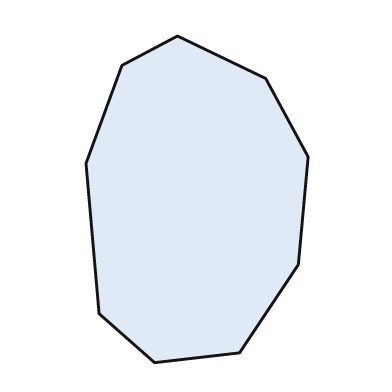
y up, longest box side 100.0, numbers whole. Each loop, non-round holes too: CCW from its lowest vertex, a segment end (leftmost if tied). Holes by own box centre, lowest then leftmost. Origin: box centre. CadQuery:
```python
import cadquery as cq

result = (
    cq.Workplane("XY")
    .moveTo(-13.0, -50.0)
    .lineTo(13.0, -47.0)
    .lineTo(31.0, -20.0)
    .lineTo(34.0, 13.0)
    .lineTo(21.0, 37.0)
    .lineTo(-6.0, 50.0)
    .lineTo(-23.0, 41.0)
    .lineTo(-34.0, 11.0)
    .lineTo(-30.0, -35.0)
    .close()
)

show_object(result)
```